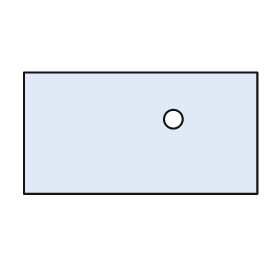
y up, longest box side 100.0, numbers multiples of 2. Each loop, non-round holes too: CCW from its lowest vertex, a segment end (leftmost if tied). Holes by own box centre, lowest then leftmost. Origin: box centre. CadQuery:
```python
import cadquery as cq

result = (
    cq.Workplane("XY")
    .moveTo(-50.0, -26.0)
    .lineTo(50.0, -26.0)
    .lineTo(50.0, 26.0)
    .lineTo(-50.0, 26.0)
    .close()
    .moveTo(14.0, 6.0)
    .circle(4.0)
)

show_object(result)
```